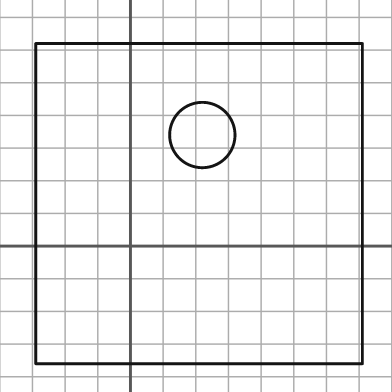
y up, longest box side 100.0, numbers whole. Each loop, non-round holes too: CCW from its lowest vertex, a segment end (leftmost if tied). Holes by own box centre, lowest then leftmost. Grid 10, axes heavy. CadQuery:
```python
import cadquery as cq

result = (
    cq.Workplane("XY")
    .moveTo(-29.0, -36.0)
    .lineTo(71.0, -36.0)
    .lineTo(71.0, 62.0)
    .lineTo(-29.0, 62.0)
    .close()
    .moveTo(22.0, 34.0)
    .circle(10.0)
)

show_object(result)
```